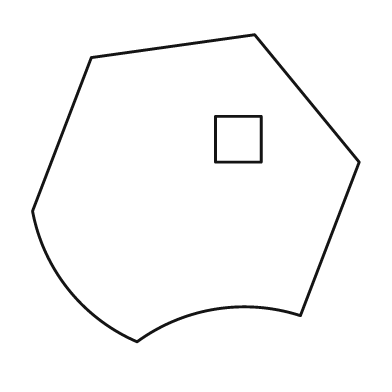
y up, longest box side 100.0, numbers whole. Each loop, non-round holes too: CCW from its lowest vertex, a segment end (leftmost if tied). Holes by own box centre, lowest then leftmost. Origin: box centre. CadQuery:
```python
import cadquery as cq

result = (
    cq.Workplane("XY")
    .moveTo(-18.0, -47.0)
    .threePointArc((6.0, -37.0), (32.0, -39.0))
    .lineTo(50.0, 8.0)
    .lineTo(18.0, 47.0)
    .lineTo(-32.0, 40.0)
    .lineTo(-50.0, -7.0)
    .threePointArc((-39.0, -31.0), (-18.0, -47.0))
    .close()
    .moveTo(6.0, 8.0)
    .lineTo(20.0, 8.0)
    .lineTo(20.0, 22.0)
    .lineTo(6.0, 22.0)
    .close()
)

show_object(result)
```